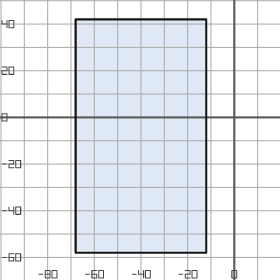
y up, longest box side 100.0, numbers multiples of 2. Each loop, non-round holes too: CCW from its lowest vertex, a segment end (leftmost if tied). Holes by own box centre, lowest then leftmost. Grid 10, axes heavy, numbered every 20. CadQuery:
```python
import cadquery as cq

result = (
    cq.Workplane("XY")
    .moveTo(-68.0, -58.0)
    .lineTo(-12.0, -58.0)
    .lineTo(-12.0, 42.0)
    .lineTo(-68.0, 42.0)
    .close()
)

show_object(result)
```